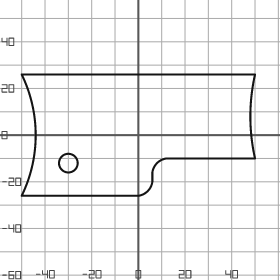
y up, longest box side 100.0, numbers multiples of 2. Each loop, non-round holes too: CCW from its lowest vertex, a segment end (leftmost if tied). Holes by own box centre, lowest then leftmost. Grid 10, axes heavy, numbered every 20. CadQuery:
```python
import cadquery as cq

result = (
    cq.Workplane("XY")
    .moveTo(-50.0, -26.0)
    .lineTo(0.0, -26.0)
    .threePointArc((4.0, -24.0), (6.0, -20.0))
    .lineTo(6.0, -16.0)
    .threePointArc((8.0, -12.0), (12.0, -10.0))
    .lineTo(50.0, -10.0)
    .threePointArc((48.0, 8.0), (50.0, 26.0))
    .lineTo(-50.0, 26.0)
    .threePointArc((-44.0, 0.0), (-50.0, -26.0))
    .close()
    .moveTo(-30.0, -12.0)
    .circle(4.0)
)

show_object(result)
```